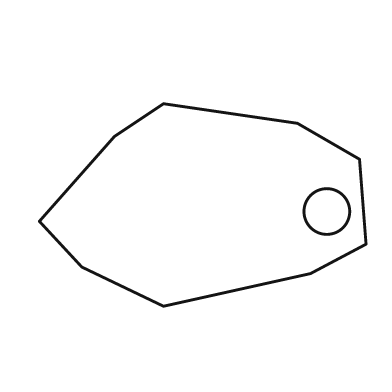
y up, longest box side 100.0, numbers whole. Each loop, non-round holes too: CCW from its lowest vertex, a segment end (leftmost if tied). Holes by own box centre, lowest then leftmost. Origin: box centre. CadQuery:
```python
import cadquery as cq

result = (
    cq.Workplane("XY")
    .moveTo(-12.0, -31.0)
    .lineTo(33.0, -21.0)
    .lineTo(50.0, -12.0)
    .lineTo(48.0, 14.0)
    .lineTo(29.0, 25.0)
    .lineTo(-12.0, 31.0)
    .lineTo(-27.0, 21.0)
    .lineTo(-50.0, -5.0)
    .lineTo(-37.0, -19.0)
    .close()
    .moveTo(38.0, -2.0)
    .circle(7.0)
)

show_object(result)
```